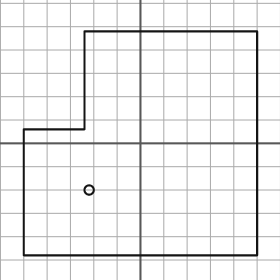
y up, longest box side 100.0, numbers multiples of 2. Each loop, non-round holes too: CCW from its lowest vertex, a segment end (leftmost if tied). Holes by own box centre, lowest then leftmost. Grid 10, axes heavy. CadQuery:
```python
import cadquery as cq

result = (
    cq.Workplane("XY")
    .moveTo(-50.0, -48.0)
    .lineTo(50.0, -48.0)
    .lineTo(50.0, 48.0)
    .lineTo(-24.0, 48.0)
    .lineTo(-24.0, 6.0)
    .lineTo(-50.0, 6.0)
    .close()
    .moveTo(-22.0, -20.0)
    .circle(2.0)
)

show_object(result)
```